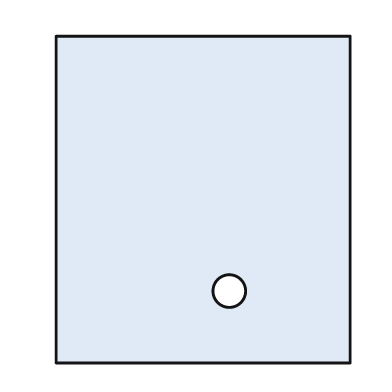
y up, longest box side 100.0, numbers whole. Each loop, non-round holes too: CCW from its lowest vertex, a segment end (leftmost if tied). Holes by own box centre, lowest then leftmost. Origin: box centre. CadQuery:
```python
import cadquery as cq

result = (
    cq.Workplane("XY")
    .moveTo(-45.0, -50.0)
    .lineTo(45.0, -50.0)
    .lineTo(45.0, 50.0)
    .lineTo(-45.0, 50.0)
    .close()
    .moveTo(8.0, -28.0)
    .circle(5.0)
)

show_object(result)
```